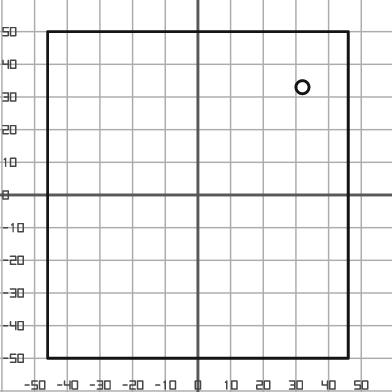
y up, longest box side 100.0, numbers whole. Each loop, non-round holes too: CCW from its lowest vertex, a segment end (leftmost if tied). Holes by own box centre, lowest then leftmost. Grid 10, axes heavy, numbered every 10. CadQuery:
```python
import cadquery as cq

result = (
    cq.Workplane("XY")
    .moveTo(-46.0, -50.0)
    .lineTo(46.0, -50.0)
    .lineTo(46.0, 50.0)
    .lineTo(-46.0, 50.0)
    .close()
    .moveTo(32.0, 33.0)
    .circle(2.0)
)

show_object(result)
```